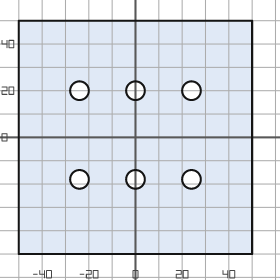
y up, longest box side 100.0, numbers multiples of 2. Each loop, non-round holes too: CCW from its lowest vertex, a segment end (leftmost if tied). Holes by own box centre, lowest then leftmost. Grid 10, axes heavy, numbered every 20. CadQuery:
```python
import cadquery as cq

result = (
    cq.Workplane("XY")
    .moveTo(-50.0, -50.0)
    .lineTo(50.0, -50.0)
    .lineTo(50.0, 50.0)
    .lineTo(-50.0, 50.0)
    .close()
    .moveTo(-24.0, -18.0)
    .circle(4.0)
    .moveTo(0.0, -18.0)
    .circle(4.0)
    .moveTo(24.0, -18.0)
    .circle(4.0)
    .moveTo(-24.0, 20.0)
    .circle(4.0)
    .moveTo(0.0, 20.0)
    .circle(4.0)
    .moveTo(24.0, 20.0)
    .circle(4.0)
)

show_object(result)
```